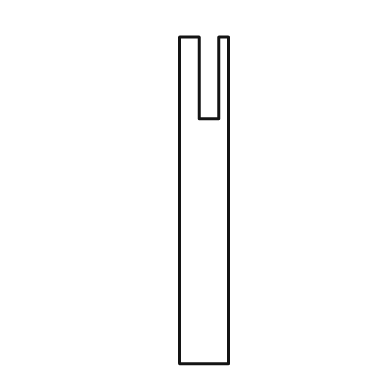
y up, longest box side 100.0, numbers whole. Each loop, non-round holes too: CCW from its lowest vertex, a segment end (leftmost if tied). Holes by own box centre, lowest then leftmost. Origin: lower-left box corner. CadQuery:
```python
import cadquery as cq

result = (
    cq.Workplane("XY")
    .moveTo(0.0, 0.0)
    .lineTo(15.0, 0.0)
    .lineTo(15.0, 100.0)
    .lineTo(12.0, 100.0)
    .lineTo(12.0, 75.0)
    .lineTo(6.0, 75.0)
    .lineTo(6.0, 100.0)
    .lineTo(0.0, 100.0)
    .close()
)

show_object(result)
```